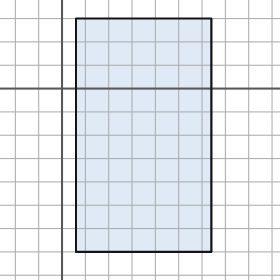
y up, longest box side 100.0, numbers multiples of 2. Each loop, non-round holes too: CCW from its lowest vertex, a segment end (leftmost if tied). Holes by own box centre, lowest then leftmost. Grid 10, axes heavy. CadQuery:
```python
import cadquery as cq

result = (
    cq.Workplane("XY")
    .moveTo(6.0, -70.0)
    .lineTo(64.0, -70.0)
    .lineTo(64.0, 30.0)
    .lineTo(6.0, 30.0)
    .close()
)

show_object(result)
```